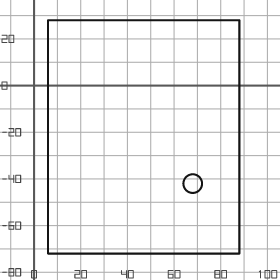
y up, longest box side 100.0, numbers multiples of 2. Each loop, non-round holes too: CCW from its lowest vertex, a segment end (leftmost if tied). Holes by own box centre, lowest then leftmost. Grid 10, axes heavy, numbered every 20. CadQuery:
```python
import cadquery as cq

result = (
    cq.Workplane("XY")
    .moveTo(6.0, -72.0)
    .lineTo(88.0, -72.0)
    .lineTo(88.0, 28.0)
    .lineTo(6.0, 28.0)
    .close()
    .moveTo(68.0, -42.0)
    .circle(4.0)
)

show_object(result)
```